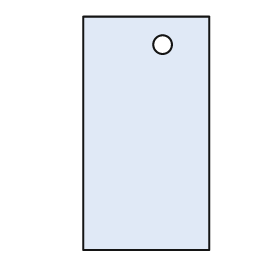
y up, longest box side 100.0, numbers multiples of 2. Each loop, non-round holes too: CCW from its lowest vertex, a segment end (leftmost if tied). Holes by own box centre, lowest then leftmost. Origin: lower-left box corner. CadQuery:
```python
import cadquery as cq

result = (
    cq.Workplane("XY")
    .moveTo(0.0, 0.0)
    .lineTo(54.0, 0.0)
    .lineTo(54.0, 100.0)
    .lineTo(0.0, 100.0)
    .close()
    .moveTo(34.0, 88.0)
    .circle(4.0)
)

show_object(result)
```